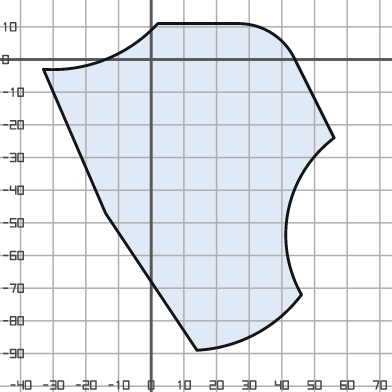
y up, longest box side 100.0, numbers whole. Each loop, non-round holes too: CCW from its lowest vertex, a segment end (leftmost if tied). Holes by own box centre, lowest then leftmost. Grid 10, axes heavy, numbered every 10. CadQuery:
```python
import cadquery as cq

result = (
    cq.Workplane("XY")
    .moveTo(14.0, -89.0)
    .threePointArc((32.0, -84.0), (46.0, -72.0))
    .threePointArc((42.0, -46.0), (56.0, -24.0))
    .lineTo(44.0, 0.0)
    .threePointArc((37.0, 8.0), (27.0, 11.0))
    .lineTo(2.0, 11.0)
    .threePointArc((-14.0, 0.0), (-33.0, -3.0))
    .lineTo(-14.0, -47.0)
    .close()
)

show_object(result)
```